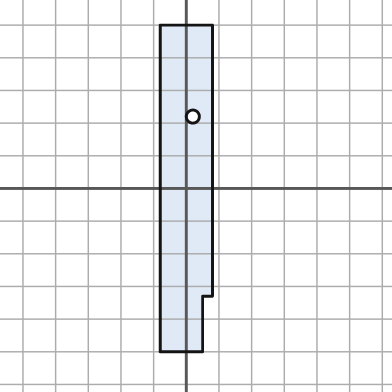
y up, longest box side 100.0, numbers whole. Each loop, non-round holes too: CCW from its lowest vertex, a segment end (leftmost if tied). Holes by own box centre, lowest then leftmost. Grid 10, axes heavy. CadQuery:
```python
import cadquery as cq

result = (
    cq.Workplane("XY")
    .moveTo(-8.0, -50.0)
    .lineTo(5.0, -50.0)
    .lineTo(5.0, -33.0)
    .lineTo(8.0, -33.0)
    .lineTo(8.0, 50.0)
    .lineTo(-8.0, 50.0)
    .close()
    .moveTo(2.0, 22.0)
    .circle(2.0)
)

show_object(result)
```